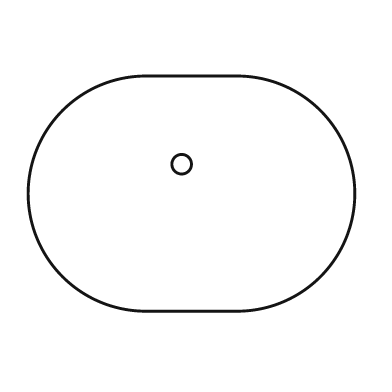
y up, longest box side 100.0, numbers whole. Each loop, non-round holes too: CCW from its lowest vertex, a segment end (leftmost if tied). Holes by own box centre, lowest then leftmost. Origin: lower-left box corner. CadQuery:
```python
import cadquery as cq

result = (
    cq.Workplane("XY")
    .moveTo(36.0, 0.0)
    .lineTo(64.0, 0.0)
    .threePointArc((100.0, 36.0), (64.0, 72.0))
    .lineTo(36.0, 72.0)
    .threePointArc((0.0, 36.0), (36.0, 0.0))
    .close()
    .moveTo(47.0, 45.0)
    .circle(3.0)
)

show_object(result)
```